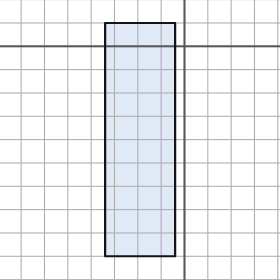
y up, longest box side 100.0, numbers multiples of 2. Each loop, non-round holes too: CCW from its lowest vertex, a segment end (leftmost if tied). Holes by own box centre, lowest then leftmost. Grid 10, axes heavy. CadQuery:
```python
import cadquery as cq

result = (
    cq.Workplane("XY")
    .moveTo(-34.0, -90.0)
    .lineTo(-4.0, -90.0)
    .lineTo(-4.0, 10.0)
    .lineTo(-34.0, 10.0)
    .close()
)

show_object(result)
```